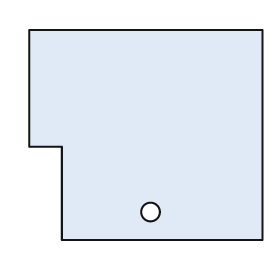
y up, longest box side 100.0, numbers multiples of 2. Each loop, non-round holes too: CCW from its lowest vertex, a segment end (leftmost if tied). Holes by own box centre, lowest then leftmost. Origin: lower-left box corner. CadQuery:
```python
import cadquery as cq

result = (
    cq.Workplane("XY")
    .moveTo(14.0, 0.0)
    .lineTo(100.0, 0.0)
    .lineTo(100.0, 90.0)
    .lineTo(0.0, 90.0)
    .lineTo(0.0, 40.0)
    .lineTo(14.0, 40.0)
    .close()
    .moveTo(52.0, 12.0)
    .circle(4.0)
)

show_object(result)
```